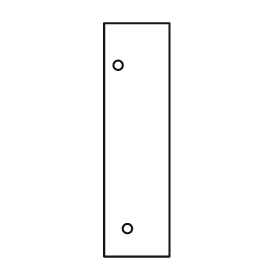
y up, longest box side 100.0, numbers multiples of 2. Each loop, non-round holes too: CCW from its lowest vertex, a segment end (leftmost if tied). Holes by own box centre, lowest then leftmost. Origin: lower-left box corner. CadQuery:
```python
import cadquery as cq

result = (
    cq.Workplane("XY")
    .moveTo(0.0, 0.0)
    .lineTo(28.0, 0.0)
    .lineTo(28.0, 100.0)
    .lineTo(0.0, 100.0)
    .close()
    .moveTo(10.0, 12.0)
    .circle(2.0)
    .moveTo(6.0, 82.0)
    .circle(2.0)
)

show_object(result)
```